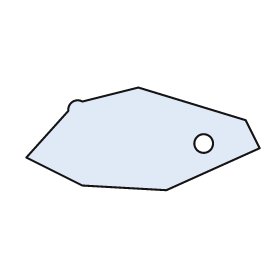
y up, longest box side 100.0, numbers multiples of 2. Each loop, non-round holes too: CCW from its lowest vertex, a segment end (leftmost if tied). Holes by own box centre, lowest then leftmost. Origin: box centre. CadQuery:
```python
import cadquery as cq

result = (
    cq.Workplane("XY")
    .moveTo(10.0, -22.0)
    .lineTo(50.0, -4.0)
    .lineTo(44.0, 8.0)
    .lineTo(-2.0, 22.0)
    .lineTo(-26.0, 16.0)
    .threePointArc((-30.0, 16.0), (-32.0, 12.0))
    .lineTo(-50.0, -8.0)
    .lineTo(-26.0, -20.0)
    .close()
    .moveTo(26.0, -2.0)
    .circle(4.0)
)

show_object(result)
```